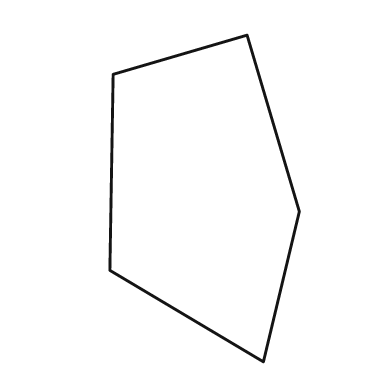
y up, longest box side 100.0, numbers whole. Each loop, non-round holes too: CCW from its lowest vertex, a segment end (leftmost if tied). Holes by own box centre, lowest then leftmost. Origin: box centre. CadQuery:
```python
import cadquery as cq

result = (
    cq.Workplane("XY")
    .moveTo(18.0, -50.0)
    .lineTo(29.0, -4.0)
    .lineTo(13.0, 50.0)
    .lineTo(-28.0, 38.0)
    .lineTo(-29.0, -22.0)
    .close()
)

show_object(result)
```